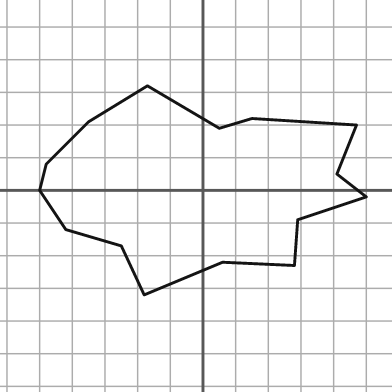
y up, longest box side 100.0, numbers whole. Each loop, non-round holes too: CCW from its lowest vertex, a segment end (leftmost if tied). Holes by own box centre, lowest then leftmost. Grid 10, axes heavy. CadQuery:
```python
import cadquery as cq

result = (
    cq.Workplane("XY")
    .moveTo(-18.0, -32.0)
    .lineTo(6.0, -22.0)
    .lineTo(28.0, -23.0)
    .lineTo(29.0, -9.0)
    .lineTo(50.0, -2.0)
    .lineTo(41.0, 5.0)
    .lineTo(47.0, 20.0)
    .lineTo(15.0, 22.0)
    .lineTo(5.0, 19.0)
    .lineTo(-17.0, 32.0)
    .lineTo(-35.0, 21.0)
    .lineTo(-48.0, 8.0)
    .lineTo(-50.0, 0.0)
    .lineTo(-42.0, -12.0)
    .lineTo(-25.0, -17.0)
    .close()
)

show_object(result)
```